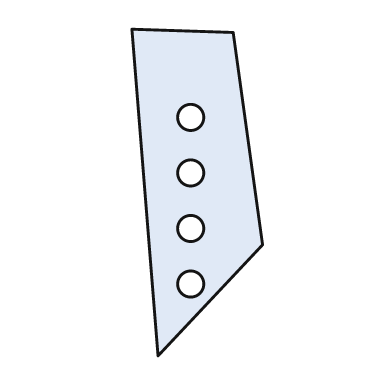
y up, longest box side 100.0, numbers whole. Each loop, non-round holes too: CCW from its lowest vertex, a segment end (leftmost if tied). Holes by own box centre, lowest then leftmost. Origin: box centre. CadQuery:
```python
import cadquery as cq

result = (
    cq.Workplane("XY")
    .moveTo(-12.0, -50.0)
    .lineTo(20.0, -16.0)
    .lineTo(11.0, 49.0)
    .lineTo(-20.0, 50.0)
    .close()
    .moveTo(-2.0, -28.0)
    .circle(4.0)
    .moveTo(-2.0, -11.0)
    .circle(4.0)
    .moveTo(-2.0, 6.0)
    .circle(4.0)
    .moveTo(-2.0, 23.0)
    .circle(4.0)
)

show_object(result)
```